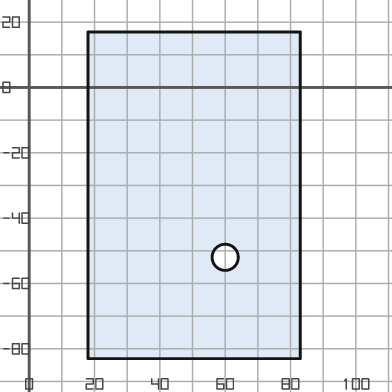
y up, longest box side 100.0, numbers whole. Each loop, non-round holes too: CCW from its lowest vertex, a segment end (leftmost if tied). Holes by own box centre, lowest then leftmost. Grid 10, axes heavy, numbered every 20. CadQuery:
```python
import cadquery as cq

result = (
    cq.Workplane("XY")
    .moveTo(18.0, -83.0)
    .lineTo(83.0, -83.0)
    .lineTo(83.0, 17.0)
    .lineTo(18.0, 17.0)
    .close()
    .moveTo(60.0, -52.0)
    .circle(4.0)
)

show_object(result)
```